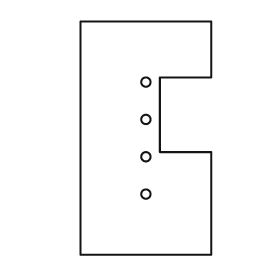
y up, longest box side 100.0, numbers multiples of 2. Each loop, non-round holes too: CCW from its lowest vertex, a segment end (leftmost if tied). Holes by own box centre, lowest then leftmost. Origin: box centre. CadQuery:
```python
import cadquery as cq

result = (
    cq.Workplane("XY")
    .moveTo(-28.0, -50.0)
    .lineTo(28.0, -50.0)
    .lineTo(28.0, -6.0)
    .lineTo(6.0, -6.0)
    .lineTo(6.0, 26.0)
    .lineTo(28.0, 26.0)
    .lineTo(28.0, 50.0)
    .lineTo(-28.0, 50.0)
    .close()
    .moveTo(0.0, -24.0)
    .circle(2.0)
    .moveTo(0.0, -8.0)
    .circle(2.0)
    .moveTo(0.0, 8.0)
    .circle(2.0)
    .moveTo(0.0, 24.0)
    .circle(2.0)
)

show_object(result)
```